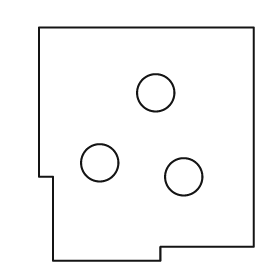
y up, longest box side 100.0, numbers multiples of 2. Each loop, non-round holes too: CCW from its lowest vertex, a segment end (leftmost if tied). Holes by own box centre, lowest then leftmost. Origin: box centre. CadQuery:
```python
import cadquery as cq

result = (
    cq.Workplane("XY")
    .moveTo(-40.0, -50.0)
    .lineTo(6.0, -50.0)
    .lineTo(6.0, -44.0)
    .lineTo(46.0, -44.0)
    .lineTo(46.0, 50.0)
    .lineTo(-46.0, 50.0)
    .lineTo(-46.0, -14.0)
    .lineTo(-40.0, -14.0)
    .close()
    .moveTo(16.0, -14.0)
    .circle(8.0)
    .moveTo(-20.0, -8.0)
    .circle(8.0)
    .moveTo(4.0, 22.0)
    .circle(8.0)
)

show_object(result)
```